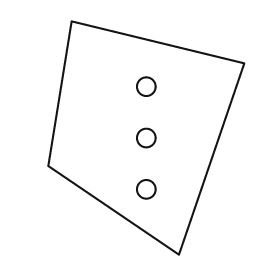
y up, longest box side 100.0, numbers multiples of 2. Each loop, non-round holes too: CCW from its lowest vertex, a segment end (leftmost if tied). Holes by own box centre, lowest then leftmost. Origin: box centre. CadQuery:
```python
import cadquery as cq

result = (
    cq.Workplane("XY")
    .moveTo(14.0, -50.0)
    .lineTo(42.0, 32.0)
    .lineTo(-32.0, 50.0)
    .lineTo(-42.0, -12.0)
    .close()
    .moveTo(0.0, -22.0)
    .circle(4.0)
    .moveTo(0.0, 0.0)
    .circle(4.0)
    .moveTo(0.0, 22.0)
    .circle(4.0)
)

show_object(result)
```